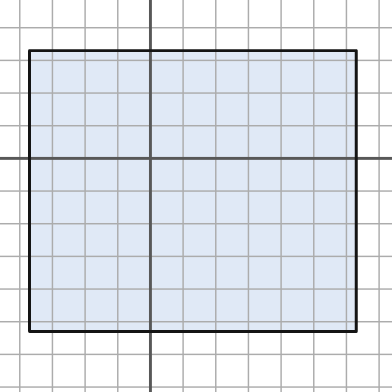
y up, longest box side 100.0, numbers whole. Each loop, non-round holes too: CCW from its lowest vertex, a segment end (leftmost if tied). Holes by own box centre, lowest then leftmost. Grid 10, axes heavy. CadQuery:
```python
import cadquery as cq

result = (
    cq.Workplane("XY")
    .moveTo(-37.0, -53.0)
    .lineTo(63.0, -53.0)
    .lineTo(63.0, 33.0)
    .lineTo(-37.0, 33.0)
    .close()
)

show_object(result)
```